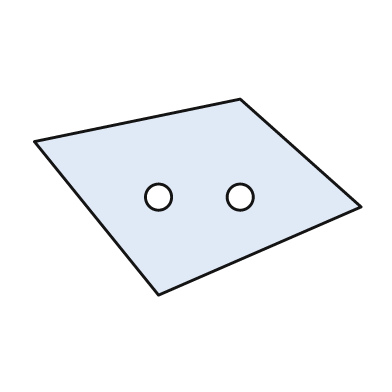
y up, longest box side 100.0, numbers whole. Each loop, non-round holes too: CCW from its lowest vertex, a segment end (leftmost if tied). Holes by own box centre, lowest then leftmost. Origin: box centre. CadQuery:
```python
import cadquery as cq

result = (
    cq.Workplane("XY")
    .moveTo(-12.0, -30.0)
    .lineTo(50.0, -3.0)
    .lineTo(13.0, 30.0)
    .lineTo(-50.0, 17.0)
    .close()
    .moveTo(-12.0, 0.0)
    .circle(4.0)
    .moveTo(13.0, 0.0)
    .circle(4.0)
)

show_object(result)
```